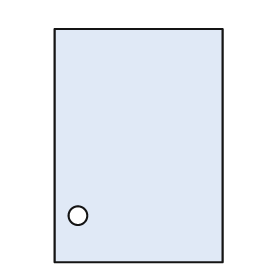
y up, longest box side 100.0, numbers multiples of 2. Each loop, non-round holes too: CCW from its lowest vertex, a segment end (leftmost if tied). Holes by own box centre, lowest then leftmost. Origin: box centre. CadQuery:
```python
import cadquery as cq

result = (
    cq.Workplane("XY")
    .moveTo(-36.0, -50.0)
    .lineTo(36.0, -50.0)
    .lineTo(36.0, 50.0)
    .lineTo(-36.0, 50.0)
    .close()
    .moveTo(-26.0, -30.0)
    .circle(4.0)
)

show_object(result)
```